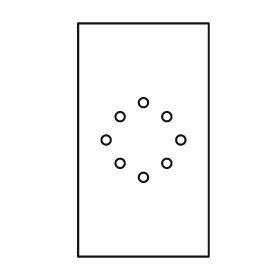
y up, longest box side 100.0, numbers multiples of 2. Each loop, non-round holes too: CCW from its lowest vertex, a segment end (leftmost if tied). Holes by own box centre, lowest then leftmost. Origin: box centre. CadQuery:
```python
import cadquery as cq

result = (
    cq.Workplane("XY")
    .moveTo(-28.0, -50.0)
    .lineTo(28.0, -50.0)
    .lineTo(28.0, 50.0)
    .lineTo(-28.0, 50.0)
    .close()
    .moveTo(0.0, -16.0)
    .circle(2.0)
    .moveTo(-10.0, -10.0)
    .circle(2.0)
    .moveTo(10.0, -10.0)
    .circle(2.0)
    .moveTo(-16.0, 0.0)
    .circle(2.0)
    .moveTo(16.0, 0.0)
    .circle(2.0)
    .moveTo(-10.0, 10.0)
    .circle(2.0)
    .moveTo(10.0, 10.0)
    .circle(2.0)
    .moveTo(0.0, 16.0)
    .circle(2.0)
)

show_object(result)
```